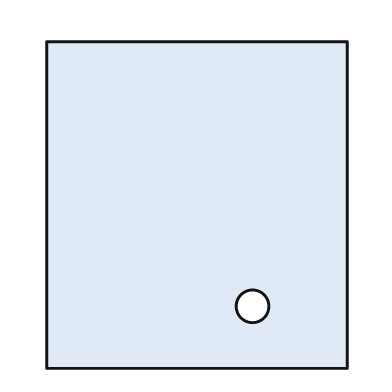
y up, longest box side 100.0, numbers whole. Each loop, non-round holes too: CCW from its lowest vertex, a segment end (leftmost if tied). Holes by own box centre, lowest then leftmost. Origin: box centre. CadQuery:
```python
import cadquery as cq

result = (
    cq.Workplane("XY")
    .moveTo(-46.0, -50.0)
    .lineTo(46.0, -50.0)
    .lineTo(46.0, 50.0)
    .lineTo(-46.0, 50.0)
    .close()
    .moveTo(17.0, -31.0)
    .circle(5.0)
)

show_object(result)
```